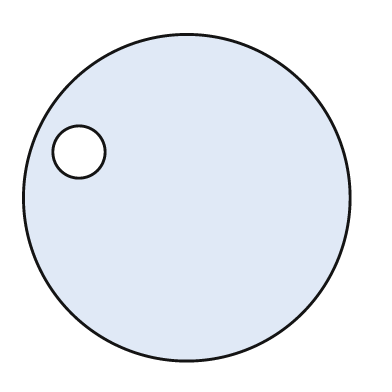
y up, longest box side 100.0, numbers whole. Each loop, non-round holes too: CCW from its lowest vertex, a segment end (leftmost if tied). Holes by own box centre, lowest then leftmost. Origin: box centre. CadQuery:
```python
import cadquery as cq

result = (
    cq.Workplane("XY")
    .moveTo(0.0, 0.0)
    .circle(50.0)
    .moveTo(-33.0, 14.0)
    .circle(8.0)
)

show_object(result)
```